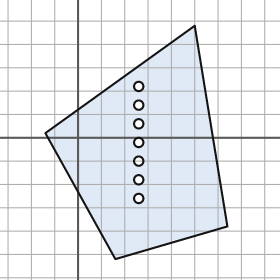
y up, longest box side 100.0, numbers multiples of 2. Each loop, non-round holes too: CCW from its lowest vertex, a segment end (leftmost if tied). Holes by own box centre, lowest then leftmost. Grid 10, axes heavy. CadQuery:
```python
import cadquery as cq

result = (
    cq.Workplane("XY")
    .moveTo(16.0, -52.0)
    .lineTo(64.0, -38.0)
    .lineTo(50.0, 48.0)
    .lineTo(-14.0, 2.0)
    .close()
    .moveTo(26.0, -26.0)
    .circle(2.0)
    .moveTo(26.0, -18.0)
    .circle(2.0)
    .moveTo(26.0, -10.0)
    .circle(2.0)
    .moveTo(26.0, -2.0)
    .circle(2.0)
    .moveTo(26.0, 6.0)
    .circle(2.0)
    .moveTo(26.0, 14.0)
    .circle(2.0)
    .moveTo(26.0, 22.0)
    .circle(2.0)
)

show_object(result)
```